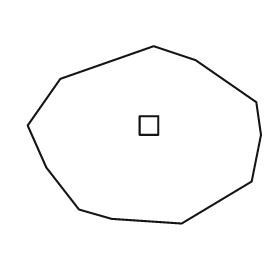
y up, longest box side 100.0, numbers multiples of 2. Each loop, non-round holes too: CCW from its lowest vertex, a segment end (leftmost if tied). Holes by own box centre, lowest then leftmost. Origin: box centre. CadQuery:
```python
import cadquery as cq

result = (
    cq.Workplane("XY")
    .moveTo(16.0, -38.0)
    .lineTo(46.0, -20.0)
    .lineTo(50.0, 0.0)
    .lineTo(48.0, 14.0)
    .lineTo(22.0, 32.0)
    .lineTo(4.0, 38.0)
    .lineTo(-36.0, 24.0)
    .lineTo(-50.0, 4.0)
    .lineTo(-42.0, -14.0)
    .lineTo(-28.0, -32.0)
    .lineTo(-14.0, -36.0)
    .close()
    .moveTo(-2.0, 0.0)
    .lineTo(6.0, 0.0)
    .lineTo(6.0, 8.0)
    .lineTo(-2.0, 8.0)
    .close()
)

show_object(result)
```